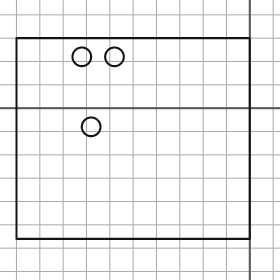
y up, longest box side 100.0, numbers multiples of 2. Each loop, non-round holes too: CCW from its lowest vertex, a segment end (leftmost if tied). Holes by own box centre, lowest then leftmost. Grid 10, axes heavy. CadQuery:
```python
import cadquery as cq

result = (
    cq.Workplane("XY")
    .moveTo(-100.0, -56.0)
    .lineTo(0.0, -56.0)
    .lineTo(0.0, 30.0)
    .lineTo(-100.0, 30.0)
    .close()
    .moveTo(-68.0, -8.0)
    .circle(4.0)
    .moveTo(-72.0, 22.0)
    .circle(4.0)
    .moveTo(-58.0, 22.0)
    .circle(4.0)
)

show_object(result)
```